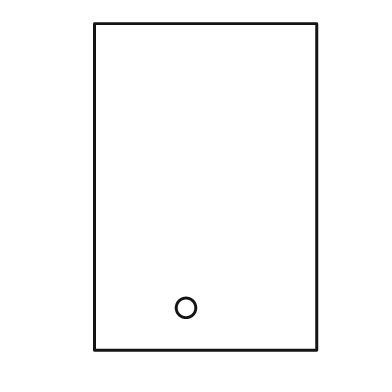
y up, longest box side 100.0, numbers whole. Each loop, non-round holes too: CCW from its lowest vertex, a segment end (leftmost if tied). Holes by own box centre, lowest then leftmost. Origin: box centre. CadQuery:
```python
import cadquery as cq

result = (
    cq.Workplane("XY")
    .moveTo(-34.0, -50.0)
    .lineTo(34.0, -50.0)
    .lineTo(34.0, 50.0)
    .lineTo(-34.0, 50.0)
    .close()
    .moveTo(-6.0, -37.0)
    .circle(3.0)
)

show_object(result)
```